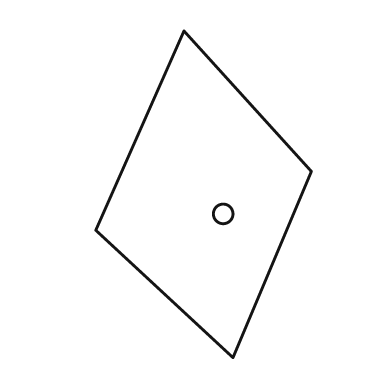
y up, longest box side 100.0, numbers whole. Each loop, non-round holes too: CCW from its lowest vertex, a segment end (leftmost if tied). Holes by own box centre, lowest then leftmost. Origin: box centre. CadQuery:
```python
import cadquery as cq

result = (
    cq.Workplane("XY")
    .moveTo(9.0, -50.0)
    .lineTo(33.0, 7.0)
    .lineTo(-6.0, 50.0)
    .lineTo(-33.0, -11.0)
    .close()
    .moveTo(6.0, -6.0)
    .circle(3.0)
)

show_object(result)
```